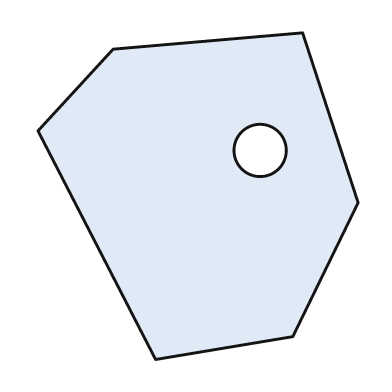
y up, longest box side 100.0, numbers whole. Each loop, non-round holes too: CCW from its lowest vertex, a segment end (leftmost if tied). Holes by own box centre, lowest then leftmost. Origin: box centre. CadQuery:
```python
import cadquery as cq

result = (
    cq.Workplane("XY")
    .moveTo(-13.0, -50.0)
    .lineTo(29.0, -43.0)
    .lineTo(49.0, -2.0)
    .lineTo(32.0, 50.0)
    .lineTo(-26.0, 45.0)
    .lineTo(-49.0, 20.0)
    .close()
    .moveTo(19.0, 14.0)
    .circle(8.0)
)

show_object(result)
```